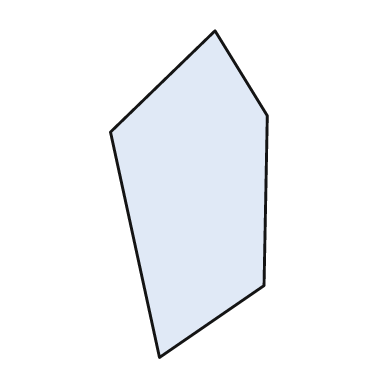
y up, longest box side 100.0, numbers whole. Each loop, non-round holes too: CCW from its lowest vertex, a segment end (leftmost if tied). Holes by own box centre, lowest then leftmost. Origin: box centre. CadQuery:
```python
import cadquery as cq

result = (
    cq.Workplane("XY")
    .moveTo(-9.0, -50.0)
    .lineTo(23.0, -28.0)
    .lineTo(24.0, 24.0)
    .lineTo(8.0, 50.0)
    .lineTo(-24.0, 19.0)
    .close()
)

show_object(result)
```